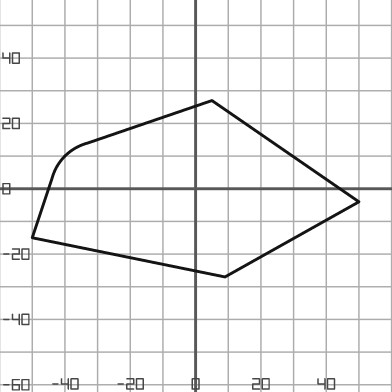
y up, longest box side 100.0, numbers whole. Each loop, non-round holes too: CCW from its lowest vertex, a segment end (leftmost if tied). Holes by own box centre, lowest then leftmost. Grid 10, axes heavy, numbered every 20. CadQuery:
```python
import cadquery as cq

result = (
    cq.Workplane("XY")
    .moveTo(9.0, -27.0)
    .lineTo(50.0, -4.0)
    .lineTo(5.0, 27.0)
    .lineTo(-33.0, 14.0)
    .threePointArc((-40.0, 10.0), (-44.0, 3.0))
    .lineTo(-50.0, -15.0)
    .close()
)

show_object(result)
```